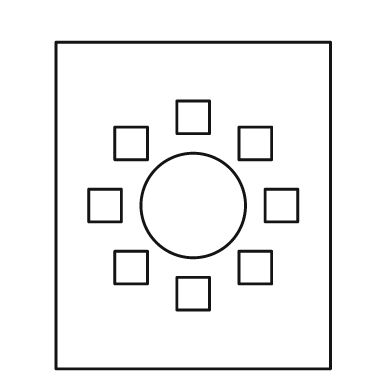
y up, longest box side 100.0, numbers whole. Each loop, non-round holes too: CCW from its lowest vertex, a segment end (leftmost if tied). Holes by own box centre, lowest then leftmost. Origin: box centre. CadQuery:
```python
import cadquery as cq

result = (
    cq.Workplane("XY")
    .moveTo(-42.0, -50.0)
    .lineTo(42.0, -50.0)
    .lineTo(42.0, 50.0)
    .lineTo(-42.0, 50.0)
    .close()
    .moveTo(-5.0, -32.0)
    .lineTo(5.0, -32.0)
    .lineTo(5.0, -22.0)
    .lineTo(-5.0, -22.0)
    .close()
    .moveTo(-24.0, -24.0)
    .lineTo(-14.0, -24.0)
    .lineTo(-14.0, -14.0)
    .lineTo(-24.0, -14.0)
    .close()
    .moveTo(14.0, -24.0)
    .lineTo(24.0, -24.0)
    .lineTo(24.0, -14.0)
    .lineTo(14.0, -14.0)
    .close()
    .moveTo(-32.0, -5.0)
    .lineTo(-22.0, -5.0)
    .lineTo(-22.0, 5.0)
    .lineTo(-32.0, 5.0)
    .close()
    .moveTo(0.0, 0.0)
    .circle(16.0)
    .moveTo(22.0, -5.0)
    .lineTo(32.0, -5.0)
    .lineTo(32.0, 5.0)
    .lineTo(22.0, 5.0)
    .close()
    .moveTo(-24.0, 14.0)
    .lineTo(-14.0, 14.0)
    .lineTo(-14.0, 24.0)
    .lineTo(-24.0, 24.0)
    .close()
    .moveTo(14.0, 14.0)
    .lineTo(24.0, 14.0)
    .lineTo(24.0, 24.0)
    .lineTo(14.0, 24.0)
    .close()
    .moveTo(-5.0, 22.0)
    .lineTo(5.0, 22.0)
    .lineTo(5.0, 32.0)
    .lineTo(-5.0, 32.0)
    .close()
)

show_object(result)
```